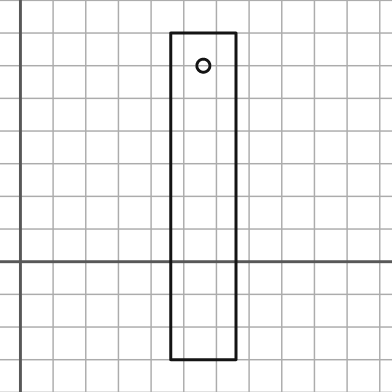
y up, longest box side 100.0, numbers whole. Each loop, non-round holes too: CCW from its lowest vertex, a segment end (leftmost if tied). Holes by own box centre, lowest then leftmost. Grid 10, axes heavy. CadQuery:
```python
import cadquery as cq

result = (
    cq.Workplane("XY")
    .moveTo(46.0, -30.0)
    .lineTo(66.0, -30.0)
    .lineTo(66.0, 70.0)
    .lineTo(46.0, 70.0)
    .close()
    .moveTo(56.0, 60.0)
    .circle(2.0)
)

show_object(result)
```